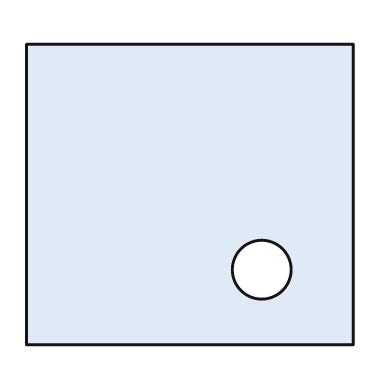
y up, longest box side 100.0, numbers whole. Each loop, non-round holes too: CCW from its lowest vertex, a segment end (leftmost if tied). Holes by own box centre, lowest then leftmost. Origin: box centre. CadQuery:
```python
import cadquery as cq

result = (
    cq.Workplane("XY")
    .moveTo(-50.0, -46.0)
    .lineTo(50.0, -46.0)
    .lineTo(50.0, 46.0)
    .lineTo(-50.0, 46.0)
    .close()
    .moveTo(22.0, -23.0)
    .circle(9.0)
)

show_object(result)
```